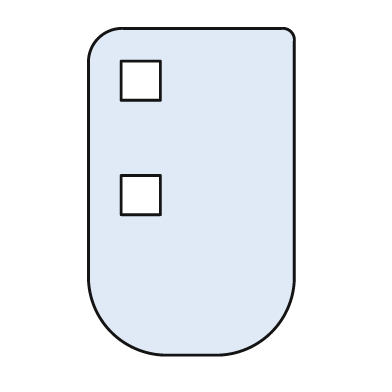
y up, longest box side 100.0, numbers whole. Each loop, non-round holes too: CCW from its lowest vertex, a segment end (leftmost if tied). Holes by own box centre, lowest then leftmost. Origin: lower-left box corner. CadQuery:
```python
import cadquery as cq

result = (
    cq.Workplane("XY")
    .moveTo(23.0, 0.0)
    .lineTo(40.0, 0.0)
    .threePointArc((56.0, 7.0), (63.0, 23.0))
    .lineTo(63.0, 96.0)
    .threePointArc((62.0, 99.0), (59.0, 100.0))
    .lineTo(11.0, 100.0)
    .threePointArc((3.0, 97.0), (0.0, 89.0))
    .lineTo(0.0, 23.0)
    .threePointArc((7.0, 7.0), (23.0, 0.0))
    .close()
    .moveTo(10.0, 43.0)
    .lineTo(22.0, 43.0)
    .lineTo(22.0, 55.0)
    .lineTo(10.0, 55.0)
    .close()
    .moveTo(10.0, 78.0)
    .lineTo(22.0, 78.0)
    .lineTo(22.0, 90.0)
    .lineTo(10.0, 90.0)
    .close()
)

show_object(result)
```